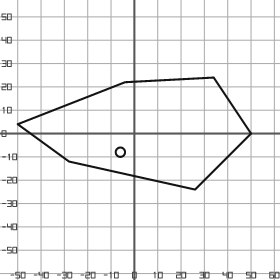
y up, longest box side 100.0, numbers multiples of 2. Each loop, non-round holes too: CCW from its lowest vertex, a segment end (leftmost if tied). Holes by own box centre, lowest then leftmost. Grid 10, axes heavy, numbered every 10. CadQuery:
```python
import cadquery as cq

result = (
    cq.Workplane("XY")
    .moveTo(26.0, -24.0)
    .lineTo(50.0, 0.0)
    .lineTo(34.0, 24.0)
    .lineTo(-4.0, 22.0)
    .lineTo(-50.0, 4.0)
    .lineTo(-28.0, -12.0)
    .close()
    .moveTo(-6.0, -8.0)
    .circle(2.0)
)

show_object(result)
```